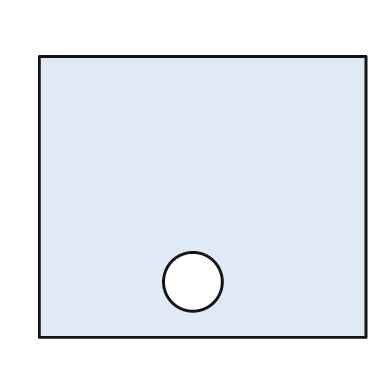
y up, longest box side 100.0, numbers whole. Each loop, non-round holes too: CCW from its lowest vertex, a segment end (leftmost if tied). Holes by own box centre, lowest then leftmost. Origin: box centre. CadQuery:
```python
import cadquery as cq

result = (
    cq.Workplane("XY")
    .moveTo(-50.0, -43.0)
    .lineTo(50.0, -43.0)
    .lineTo(50.0, 43.0)
    .lineTo(-50.0, 43.0)
    .close()
    .moveTo(-3.0, -26.0)
    .circle(9.0)
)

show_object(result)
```